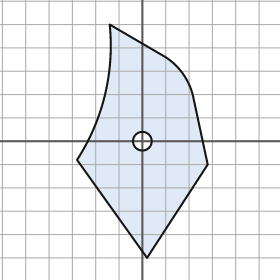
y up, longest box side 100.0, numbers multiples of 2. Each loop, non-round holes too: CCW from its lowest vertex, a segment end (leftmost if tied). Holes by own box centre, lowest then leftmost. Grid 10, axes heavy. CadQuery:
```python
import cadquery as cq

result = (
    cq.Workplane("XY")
    .moveTo(2.0, -50.0)
    .lineTo(28.0, -10.0)
    .lineTo(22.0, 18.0)
    .threePointArc((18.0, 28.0), (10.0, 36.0))
    .lineTo(-14.0, 50.0)
    .threePointArc((-16.0, 20.0), (-28.0, -8.0))
    .close()
    .moveTo(0.0, 0.0)
    .circle(4.0)
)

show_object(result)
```